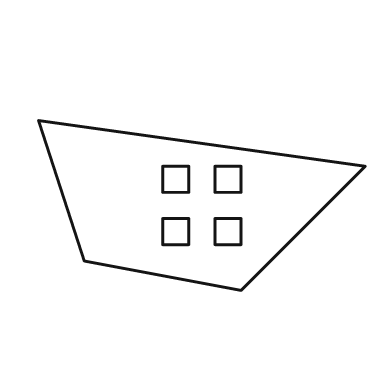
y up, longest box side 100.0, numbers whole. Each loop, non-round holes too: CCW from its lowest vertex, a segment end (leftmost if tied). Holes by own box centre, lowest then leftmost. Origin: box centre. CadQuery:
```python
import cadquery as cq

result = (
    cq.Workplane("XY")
    .moveTo(12.0, -26.0)
    .lineTo(50.0, 12.0)
    .lineTo(-50.0, 26.0)
    .lineTo(-36.0, -17.0)
    .close()
    .moveTo(-12.0, -12.0)
    .lineTo(-4.0, -12.0)
    .lineTo(-4.0, -4.0)
    .lineTo(-12.0, -4.0)
    .close()
    .moveTo(4.0, -12.0)
    .lineTo(12.0, -12.0)
    .lineTo(12.0, -4.0)
    .lineTo(4.0, -4.0)
    .close()
    .moveTo(-12.0, 4.0)
    .lineTo(-4.0, 4.0)
    .lineTo(-4.0, 12.0)
    .lineTo(-12.0, 12.0)
    .close()
    .moveTo(4.0, 4.0)
    .lineTo(12.0, 4.0)
    .lineTo(12.0, 12.0)
    .lineTo(4.0, 12.0)
    .close()
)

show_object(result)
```